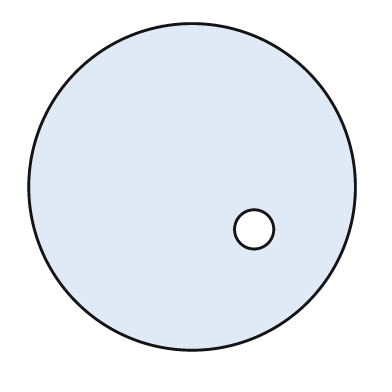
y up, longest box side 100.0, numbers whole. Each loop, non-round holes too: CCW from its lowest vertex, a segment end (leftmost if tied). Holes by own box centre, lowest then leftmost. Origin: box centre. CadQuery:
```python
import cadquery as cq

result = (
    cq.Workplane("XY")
    .moveTo(0.0, 0.0)
    .circle(50.0)
    .moveTo(19.0, -13.0)
    .circle(6.0)
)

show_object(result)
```